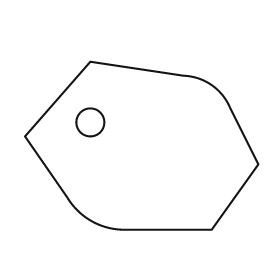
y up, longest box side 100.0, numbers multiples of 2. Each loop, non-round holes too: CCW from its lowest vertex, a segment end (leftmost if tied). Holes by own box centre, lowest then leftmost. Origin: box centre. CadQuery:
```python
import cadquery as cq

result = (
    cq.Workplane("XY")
    .moveTo(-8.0, -36.0)
    .lineTo(30.0, -36.0)
    .lineTo(50.0, -8.0)
    .lineTo(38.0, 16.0)
    .threePointArc((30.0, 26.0), (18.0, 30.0))
    .lineTo(-22.0, 36.0)
    .lineTo(-50.0, 4.0)
    .lineTo(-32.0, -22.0)
    .threePointArc((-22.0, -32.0), (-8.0, -36.0))
    .close()
    .moveTo(-22.0, 10.0)
    .circle(6.0)
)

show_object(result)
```